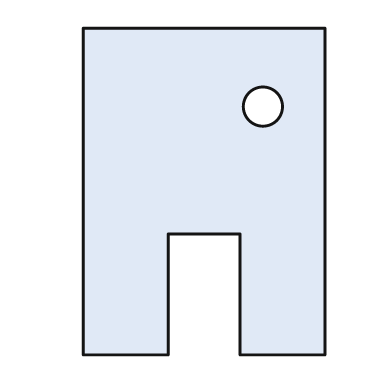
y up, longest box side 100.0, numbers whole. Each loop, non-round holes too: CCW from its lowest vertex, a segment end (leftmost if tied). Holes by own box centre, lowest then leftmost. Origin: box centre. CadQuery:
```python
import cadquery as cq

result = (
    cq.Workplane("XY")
    .moveTo(-37.0, -50.0)
    .lineTo(-11.0, -50.0)
    .lineTo(-11.0, -13.0)
    .lineTo(11.0, -13.0)
    .lineTo(11.0, -50.0)
    .lineTo(37.0, -50.0)
    .lineTo(37.0, 50.0)
    .lineTo(-37.0, 50.0)
    .close()
    .moveTo(18.0, 26.0)
    .circle(6.0)
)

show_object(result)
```